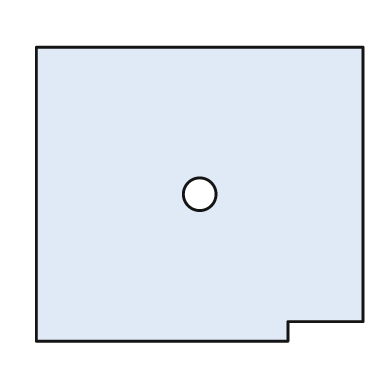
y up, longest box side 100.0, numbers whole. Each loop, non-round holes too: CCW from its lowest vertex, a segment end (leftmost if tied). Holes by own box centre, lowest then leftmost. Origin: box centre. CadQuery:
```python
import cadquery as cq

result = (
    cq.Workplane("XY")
    .moveTo(-50.0, -45.0)
    .lineTo(27.0, -45.0)
    .lineTo(27.0, -39.0)
    .lineTo(50.0, -39.0)
    .lineTo(50.0, 45.0)
    .lineTo(-50.0, 45.0)
    .close()
    .moveTo(0.0, 0.0)
    .circle(5.0)
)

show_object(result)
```